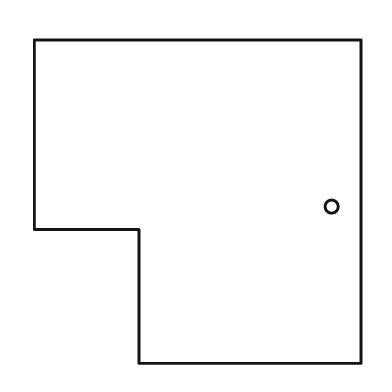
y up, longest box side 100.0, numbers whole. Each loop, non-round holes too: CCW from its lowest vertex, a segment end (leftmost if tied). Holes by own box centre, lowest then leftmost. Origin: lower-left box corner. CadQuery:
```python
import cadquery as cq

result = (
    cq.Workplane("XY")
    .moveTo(32.0, 0.0)
    .lineTo(100.0, 0.0)
    .lineTo(100.0, 99.0)
    .lineTo(0.0, 99.0)
    .lineTo(0.0, 41.0)
    .lineTo(32.0, 41.0)
    .close()
    .moveTo(91.0, 48.0)
    .circle(2.0)
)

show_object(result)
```